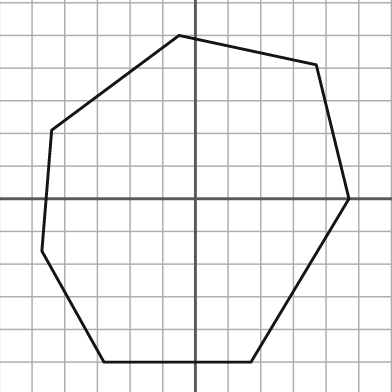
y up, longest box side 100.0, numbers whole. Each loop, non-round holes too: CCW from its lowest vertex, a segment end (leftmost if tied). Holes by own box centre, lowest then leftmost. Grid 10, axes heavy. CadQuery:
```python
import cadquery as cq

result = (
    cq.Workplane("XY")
    .moveTo(-28.0, -50.0)
    .lineTo(17.0, -50.0)
    .lineTo(47.0, 0.0)
    .lineTo(37.0, 41.0)
    .lineTo(-5.0, 50.0)
    .lineTo(-44.0, 21.0)
    .lineTo(-47.0, -16.0)
    .close()
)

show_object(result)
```